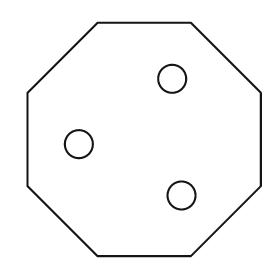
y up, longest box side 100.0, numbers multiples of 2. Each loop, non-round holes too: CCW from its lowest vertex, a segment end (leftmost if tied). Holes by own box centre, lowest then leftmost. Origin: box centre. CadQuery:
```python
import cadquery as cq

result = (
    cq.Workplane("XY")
    .moveTo(-20.0, -50.0)
    .lineTo(20.0, -50.0)
    .lineTo(50.0, -20.0)
    .lineTo(50.0, 20.0)
    .lineTo(20.0, 50.0)
    .lineTo(-20.0, 50.0)
    .lineTo(-50.0, 20.0)
    .lineTo(-50.0, -20.0)
    .close()
    .moveTo(16.0, -24.0)
    .circle(6.0)
    .moveTo(-28.0, -2.0)
    .circle(6.0)
    .moveTo(12.0, 26.0)
    .circle(6.0)
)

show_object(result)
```